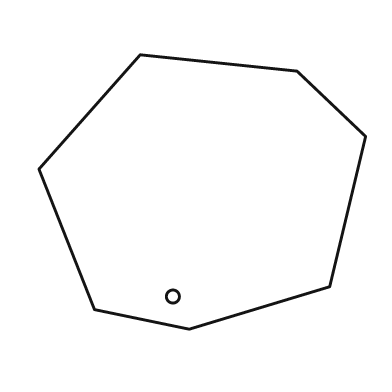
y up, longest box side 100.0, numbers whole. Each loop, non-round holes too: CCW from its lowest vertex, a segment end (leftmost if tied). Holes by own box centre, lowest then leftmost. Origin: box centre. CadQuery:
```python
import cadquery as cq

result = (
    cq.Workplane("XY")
    .moveTo(-4.0, -42.0)
    .lineTo(39.0, -29.0)
    .lineTo(50.0, 17.0)
    .lineTo(29.0, 37.0)
    .lineTo(-19.0, 42.0)
    .lineTo(-50.0, 7.0)
    .lineTo(-33.0, -36.0)
    .close()
    .moveTo(-9.0, -32.0)
    .circle(2.0)
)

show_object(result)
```